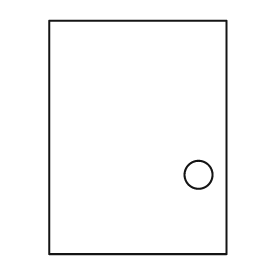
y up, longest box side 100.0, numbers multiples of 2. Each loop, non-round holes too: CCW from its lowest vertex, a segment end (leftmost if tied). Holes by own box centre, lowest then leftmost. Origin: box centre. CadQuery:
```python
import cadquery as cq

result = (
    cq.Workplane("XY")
    .moveTo(-38.0, -50.0)
    .lineTo(38.0, -50.0)
    .lineTo(38.0, 50.0)
    .lineTo(-38.0, 50.0)
    .close()
    .moveTo(26.0, -16.0)
    .circle(6.0)
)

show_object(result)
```